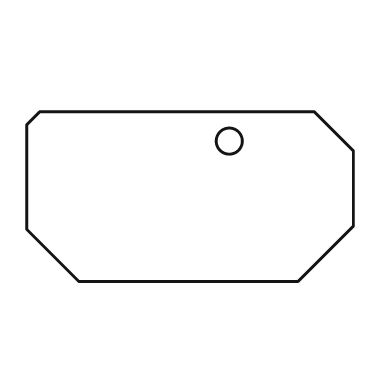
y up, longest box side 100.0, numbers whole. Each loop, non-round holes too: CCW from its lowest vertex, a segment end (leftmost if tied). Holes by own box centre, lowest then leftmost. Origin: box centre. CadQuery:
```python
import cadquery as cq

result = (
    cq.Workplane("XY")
    .moveTo(-34.0, -26.0)
    .lineTo(33.0, -26.0)
    .lineTo(50.0, -9.0)
    .lineTo(50.0, 14.0)
    .lineTo(38.0, 26.0)
    .lineTo(-46.0, 26.0)
    .lineTo(-50.0, 22.0)
    .lineTo(-50.0, -10.0)
    .close()
    .moveTo(12.0, 17.0)
    .circle(4.0)
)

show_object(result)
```